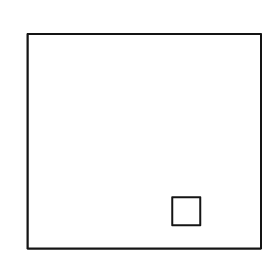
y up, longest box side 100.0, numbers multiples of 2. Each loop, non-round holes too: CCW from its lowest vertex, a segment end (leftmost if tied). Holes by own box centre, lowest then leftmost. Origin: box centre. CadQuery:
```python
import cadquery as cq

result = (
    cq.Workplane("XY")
    .moveTo(-50.0, -46.0)
    .lineTo(50.0, -46.0)
    .lineTo(50.0, 46.0)
    .lineTo(-50.0, 46.0)
    .close()
    .moveTo(12.0, -36.0)
    .lineTo(24.0, -36.0)
    .lineTo(24.0, -24.0)
    .lineTo(12.0, -24.0)
    .close()
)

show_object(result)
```